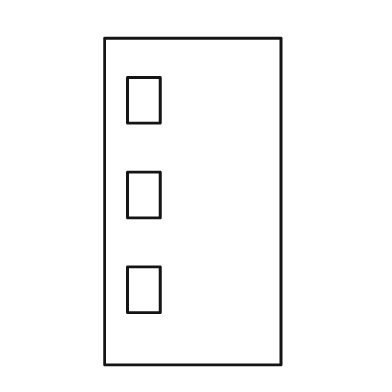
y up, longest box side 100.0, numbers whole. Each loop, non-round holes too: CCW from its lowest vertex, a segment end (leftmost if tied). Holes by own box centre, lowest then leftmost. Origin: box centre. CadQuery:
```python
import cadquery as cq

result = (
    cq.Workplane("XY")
    .moveTo(-27.0, -50.0)
    .lineTo(27.0, -50.0)
    .lineTo(27.0, 50.0)
    .lineTo(-27.0, 50.0)
    .close()
    .moveTo(-20.0, -34.0)
    .lineTo(-10.0, -34.0)
    .lineTo(-10.0, -20.0)
    .lineTo(-20.0, -20.0)
    .close()
    .moveTo(-20.0, -5.0)
    .lineTo(-10.0, -5.0)
    .lineTo(-10.0, 9.0)
    .lineTo(-20.0, 9.0)
    .close()
    .moveTo(-20.0, 24.0)
    .lineTo(-10.0, 24.0)
    .lineTo(-10.0, 38.0)
    .lineTo(-20.0, 38.0)
    .close()
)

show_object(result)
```